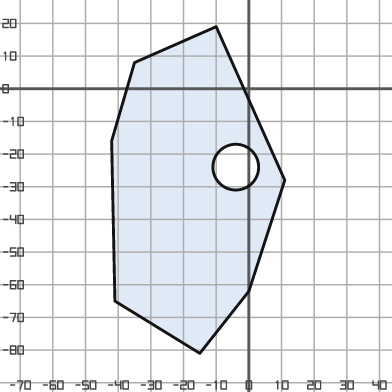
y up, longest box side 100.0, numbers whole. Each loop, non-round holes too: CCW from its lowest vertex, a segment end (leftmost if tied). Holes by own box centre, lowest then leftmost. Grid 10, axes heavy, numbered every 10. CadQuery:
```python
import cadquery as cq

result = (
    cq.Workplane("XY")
    .moveTo(-15.0, -81.0)
    .lineTo(0.0, -62.0)
    .lineTo(11.0, -28.0)
    .lineTo(-10.0, 19.0)
    .lineTo(-35.0, 8.0)
    .lineTo(-42.0, -16.0)
    .lineTo(-41.0, -65.0)
    .close()
    .moveTo(-4.0, -24.0)
    .circle(7.0)
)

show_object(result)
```